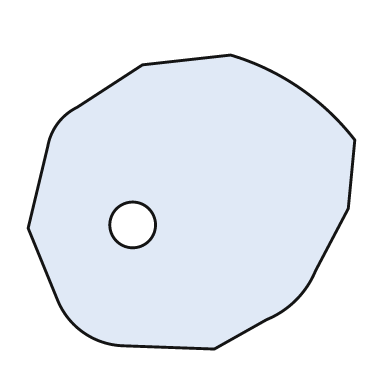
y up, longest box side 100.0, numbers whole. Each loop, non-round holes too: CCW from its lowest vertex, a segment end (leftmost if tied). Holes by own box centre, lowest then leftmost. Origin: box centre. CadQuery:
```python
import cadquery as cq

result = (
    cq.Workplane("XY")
    .moveTo(7.0, -45.0)
    .lineTo(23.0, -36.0)
    .threePointArc((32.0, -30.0), (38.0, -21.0))
    .lineTo(48.0, -2.0)
    .lineTo(50.0, 19.0)
    .threePointArc((33.0, 35.0), (12.0, 45.0))
    .lineTo(-15.0, 42.0)
    .lineTo(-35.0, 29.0)
    .threePointArc((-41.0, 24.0), (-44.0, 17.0))
    .lineTo(-50.0, -8.0)
    .lineTo(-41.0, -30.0)
    .threePointArc((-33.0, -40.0), (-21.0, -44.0))
    .close()
    .moveTo(-18.0, -7.0)
    .circle(7.0)
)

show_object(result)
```